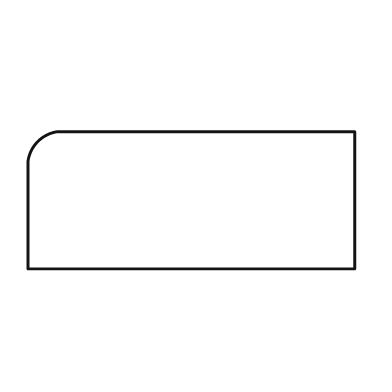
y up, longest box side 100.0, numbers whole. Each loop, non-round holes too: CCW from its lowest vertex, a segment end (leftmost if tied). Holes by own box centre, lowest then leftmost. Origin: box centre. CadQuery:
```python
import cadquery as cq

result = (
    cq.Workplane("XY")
    .moveTo(-50.0, -21.0)
    .lineTo(50.0, -21.0)
    .lineTo(50.0, 21.0)
    .lineTo(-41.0, 21.0)
    .threePointArc((-47.0, 18.0), (-50.0, 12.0))
    .close()
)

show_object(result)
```